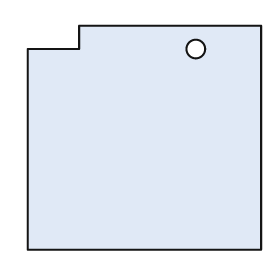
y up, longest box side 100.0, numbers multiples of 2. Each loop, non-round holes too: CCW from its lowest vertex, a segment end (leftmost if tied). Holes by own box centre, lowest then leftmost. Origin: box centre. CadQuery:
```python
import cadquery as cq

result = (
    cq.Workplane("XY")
    .moveTo(-50.0, -48.0)
    .lineTo(50.0, -48.0)
    .lineTo(50.0, 48.0)
    .lineTo(-28.0, 48.0)
    .lineTo(-28.0, 38.0)
    .lineTo(-50.0, 38.0)
    .close()
    .moveTo(22.0, 38.0)
    .circle(4.0)
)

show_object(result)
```